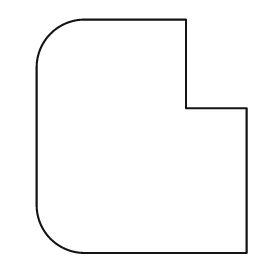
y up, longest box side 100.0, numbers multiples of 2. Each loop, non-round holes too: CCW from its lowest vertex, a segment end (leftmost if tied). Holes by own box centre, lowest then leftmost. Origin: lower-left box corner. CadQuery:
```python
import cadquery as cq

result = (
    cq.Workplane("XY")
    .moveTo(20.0, 0.0)
    .lineTo(90.0, 0.0)
    .lineTo(90.0, 62.0)
    .lineTo(64.0, 62.0)
    .lineTo(64.0, 100.0)
    .lineTo(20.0, 100.0)
    .threePointArc((6.0, 94.0), (0.0, 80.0))
    .lineTo(0.0, 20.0)
    .threePointArc((6.0, 6.0), (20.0, 0.0))
    .close()
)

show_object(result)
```